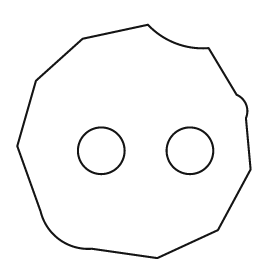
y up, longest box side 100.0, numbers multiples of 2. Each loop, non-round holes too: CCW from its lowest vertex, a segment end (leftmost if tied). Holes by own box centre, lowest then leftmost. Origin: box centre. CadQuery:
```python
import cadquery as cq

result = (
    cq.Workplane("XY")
    .moveTo(10.0, -50.0)
    .lineTo(36.0, -38.0)
    .lineTo(50.0, -12.0)
    .lineTo(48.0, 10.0)
    .threePointArc((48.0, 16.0), (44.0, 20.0))
    .lineTo(32.0, 40.0)
    .threePointArc((18.0, 42.0), (6.0, 50.0))
    .lineTo(-22.0, 44.0)
    .lineTo(-42.0, 26.0)
    .lineTo(-50.0, -2.0)
    .lineTo(-40.0, -30.0)
    .threePointArc((-32.0, -42.0), (-18.0, -46.0))
    .close()
    .moveTo(-14.0, -4.0)
    .circle(10.0)
    .moveTo(24.0, -4.0)
    .circle(10.0)
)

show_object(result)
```